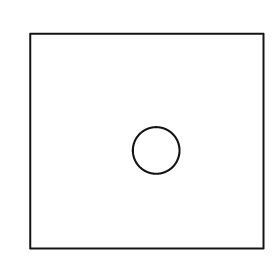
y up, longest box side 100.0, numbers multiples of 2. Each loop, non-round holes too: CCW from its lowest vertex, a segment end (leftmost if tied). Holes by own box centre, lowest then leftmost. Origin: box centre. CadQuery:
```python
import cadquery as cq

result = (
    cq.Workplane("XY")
    .moveTo(-50.0, -46.0)
    .lineTo(50.0, -46.0)
    .lineTo(50.0, 46.0)
    .lineTo(-50.0, 46.0)
    .close()
    .moveTo(4.0, -4.0)
    .circle(10.0)
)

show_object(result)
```